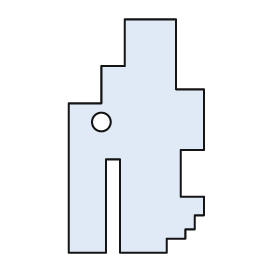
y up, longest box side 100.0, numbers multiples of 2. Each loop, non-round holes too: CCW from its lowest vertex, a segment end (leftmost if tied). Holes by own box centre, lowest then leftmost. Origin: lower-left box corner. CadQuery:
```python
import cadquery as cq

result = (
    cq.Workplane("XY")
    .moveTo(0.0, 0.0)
    .lineTo(16.0, 0.0)
    .lineTo(16.0, 40.0)
    .lineTo(22.0, 40.0)
    .lineTo(22.0, 0.0)
    .lineTo(42.0, 0.0)
    .lineTo(42.0, 6.0)
    .lineTo(50.0, 6.0)
    .lineTo(50.0, 10.0)
    .lineTo(54.0, 10.0)
    .lineTo(54.0, 16.0)
    .lineTo(58.0, 16.0)
    .lineTo(58.0, 24.0)
    .lineTo(48.0, 24.0)
    .lineTo(48.0, 44.0)
    .lineTo(58.0, 44.0)
    .lineTo(58.0, 70.0)
    .lineTo(46.0, 70.0)
    .lineTo(46.0, 100.0)
    .lineTo(24.0, 100.0)
    .lineTo(24.0, 80.0)
    .lineTo(14.0, 80.0)
    .lineTo(14.0, 64.0)
    .lineTo(0.0, 64.0)
    .close()
    .moveTo(14.0, 56.0)
    .circle(4.0)
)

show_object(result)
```